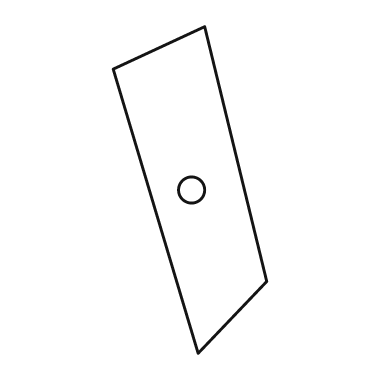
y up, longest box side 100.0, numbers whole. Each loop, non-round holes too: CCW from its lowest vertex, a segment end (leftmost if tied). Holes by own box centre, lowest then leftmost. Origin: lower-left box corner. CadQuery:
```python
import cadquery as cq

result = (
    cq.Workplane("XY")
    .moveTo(26.0, 0.0)
    .lineTo(47.0, 22.0)
    .lineTo(28.0, 100.0)
    .lineTo(0.0, 87.0)
    .close()
    .moveTo(24.0, 50.0)
    .circle(4.0)
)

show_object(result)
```